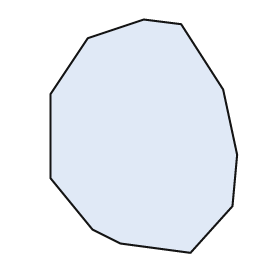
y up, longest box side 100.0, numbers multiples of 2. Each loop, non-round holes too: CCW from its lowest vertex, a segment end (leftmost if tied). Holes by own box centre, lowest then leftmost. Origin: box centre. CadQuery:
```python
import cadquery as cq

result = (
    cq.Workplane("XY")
    .moveTo(20.0, -50.0)
    .lineTo(38.0, -30.0)
    .lineTo(40.0, -8.0)
    .lineTo(34.0, 20.0)
    .lineTo(16.0, 48.0)
    .lineTo(0.0, 50.0)
    .lineTo(-24.0, 42.0)
    .lineTo(-40.0, 18.0)
    .lineTo(-40.0, -18.0)
    .lineTo(-22.0, -40.0)
    .lineTo(-10.0, -46.0)
    .close()
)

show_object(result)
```